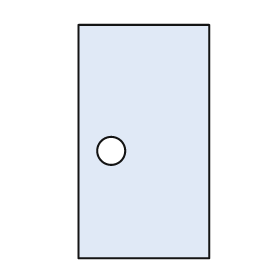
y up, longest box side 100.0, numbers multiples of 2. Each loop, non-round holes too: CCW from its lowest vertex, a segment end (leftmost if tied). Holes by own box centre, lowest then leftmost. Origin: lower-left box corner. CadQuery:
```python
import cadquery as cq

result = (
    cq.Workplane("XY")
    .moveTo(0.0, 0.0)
    .lineTo(56.0, 0.0)
    .lineTo(56.0, 100.0)
    .lineTo(0.0, 100.0)
    .close()
    .moveTo(14.0, 46.0)
    .circle(6.0)
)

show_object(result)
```